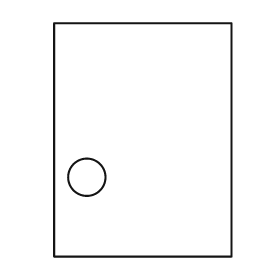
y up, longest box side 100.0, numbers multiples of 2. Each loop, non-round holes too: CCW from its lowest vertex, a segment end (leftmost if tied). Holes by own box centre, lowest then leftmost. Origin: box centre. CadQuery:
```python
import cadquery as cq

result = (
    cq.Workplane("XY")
    .moveTo(-38.0, -50.0)
    .lineTo(38.0, -50.0)
    .lineTo(38.0, 50.0)
    .lineTo(-38.0, 50.0)
    .close()
    .moveTo(-24.0, -16.0)
    .circle(8.0)
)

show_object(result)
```